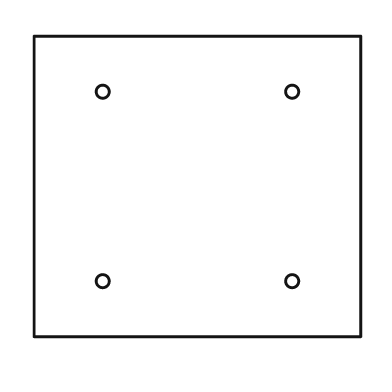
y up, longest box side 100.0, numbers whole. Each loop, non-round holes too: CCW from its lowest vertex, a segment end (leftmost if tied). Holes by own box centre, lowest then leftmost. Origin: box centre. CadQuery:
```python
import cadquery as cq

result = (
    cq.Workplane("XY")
    .moveTo(-50.0, -46.0)
    .lineTo(50.0, -46.0)
    .lineTo(50.0, 46.0)
    .lineTo(-50.0, 46.0)
    .close()
    .moveTo(-29.0, -29.0)
    .circle(2.0)
    .moveTo(29.0, -29.0)
    .circle(2.0)
    .moveTo(-29.0, 29.0)
    .circle(2.0)
    .moveTo(29.0, 29.0)
    .circle(2.0)
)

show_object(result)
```